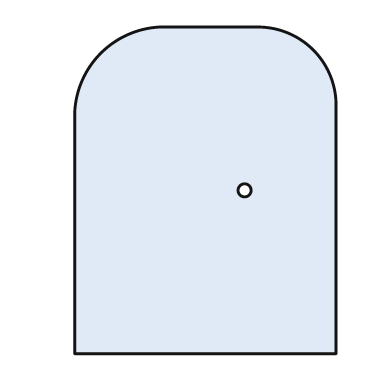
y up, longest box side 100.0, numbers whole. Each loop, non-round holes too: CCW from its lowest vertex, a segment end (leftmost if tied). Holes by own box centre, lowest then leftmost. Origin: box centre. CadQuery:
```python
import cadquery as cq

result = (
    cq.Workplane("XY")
    .moveTo(-40.0, -50.0)
    .lineTo(40.0, -50.0)
    .lineTo(40.0, 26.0)
    .threePointArc((33.0, 43.0), (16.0, 50.0))
    .lineTo(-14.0, 50.0)
    .threePointArc((-32.0, 42.0), (-40.0, 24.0))
    .close()
    .moveTo(12.0, 0.0)
    .circle(2.0)
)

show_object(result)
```